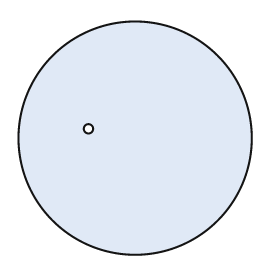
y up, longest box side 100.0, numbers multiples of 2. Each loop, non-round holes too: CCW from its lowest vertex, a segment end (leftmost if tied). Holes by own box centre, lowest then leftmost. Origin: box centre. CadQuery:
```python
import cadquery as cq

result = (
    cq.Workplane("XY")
    .moveTo(0.0, 0.0)
    .circle(50.0)
    .moveTo(-20.0, 4.0)
    .circle(2.0)
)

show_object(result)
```